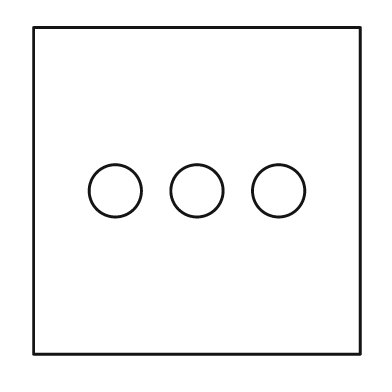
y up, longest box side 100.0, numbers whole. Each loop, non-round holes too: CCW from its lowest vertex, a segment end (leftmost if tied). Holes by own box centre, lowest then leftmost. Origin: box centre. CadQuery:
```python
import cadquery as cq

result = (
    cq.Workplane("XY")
    .moveTo(-50.0, -50.0)
    .lineTo(50.0, -50.0)
    .lineTo(50.0, 50.0)
    .lineTo(-50.0, 50.0)
    .close()
    .moveTo(-25.0, 0.0)
    .circle(8.0)
    .moveTo(0.0, 0.0)
    .circle(8.0)
    .moveTo(25.0, 0.0)
    .circle(8.0)
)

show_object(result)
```